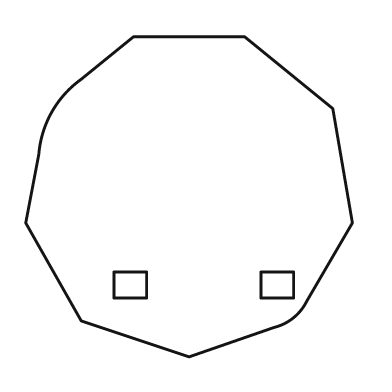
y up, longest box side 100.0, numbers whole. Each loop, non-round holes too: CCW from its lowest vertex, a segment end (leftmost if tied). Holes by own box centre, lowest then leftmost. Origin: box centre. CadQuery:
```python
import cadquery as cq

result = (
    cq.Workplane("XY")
    .moveTo(0.0, -49.0)
    .lineTo(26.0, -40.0)
    .threePointArc((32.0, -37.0), (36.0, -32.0))
    .lineTo(50.0, -8.0)
    .lineTo(44.0, 27.0)
    .lineTo(17.0, 49.0)
    .lineTo(-17.0, 49.0)
    .lineTo(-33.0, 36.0)
    .threePointArc((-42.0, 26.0), (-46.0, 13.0))
    .lineTo(-50.0, -8.0)
    .lineTo(-33.0, -38.0)
    .close()
    .moveTo(-23.0, -31.0)
    .lineTo(-13.0, -31.0)
    .lineTo(-13.0, -23.0)
    .lineTo(-23.0, -23.0)
    .close()
    .moveTo(22.0, -31.0)
    .lineTo(32.0, -31.0)
    .lineTo(32.0, -23.0)
    .lineTo(22.0, -23.0)
    .close()
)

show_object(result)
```